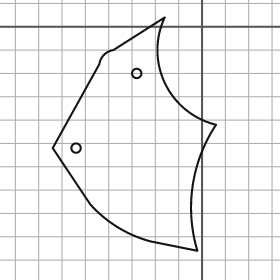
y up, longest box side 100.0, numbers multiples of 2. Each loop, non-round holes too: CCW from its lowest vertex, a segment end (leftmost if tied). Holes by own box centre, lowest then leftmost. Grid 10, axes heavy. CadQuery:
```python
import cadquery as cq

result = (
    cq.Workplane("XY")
    .moveTo(-2.0, -96.0)
    .threePointArc((-4.0, -68.0), (6.0, -42.0))
    .threePointArc((-16.0, -24.0), (-16.0, 4.0))
    .lineTo(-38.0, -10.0)
    .threePointArc((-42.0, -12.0), (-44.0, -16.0))
    .lineTo(-64.0, -52.0)
    .lineTo(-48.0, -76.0)
    .threePointArc((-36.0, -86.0), (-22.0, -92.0))
    .close()
    .moveTo(-54.0, -52.0)
    .circle(2.0)
    .moveTo(-28.0, -20.0)
    .circle(2.0)
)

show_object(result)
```